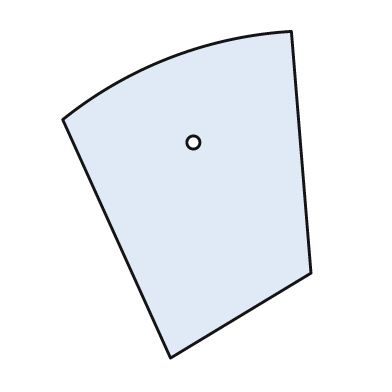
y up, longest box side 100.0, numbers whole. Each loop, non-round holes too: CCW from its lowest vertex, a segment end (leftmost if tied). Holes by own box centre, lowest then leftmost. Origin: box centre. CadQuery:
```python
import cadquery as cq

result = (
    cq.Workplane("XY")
    .moveTo(-5.0, -50.0)
    .lineTo(38.0, -24.0)
    .lineTo(32.0, 50.0)
    .threePointArc((-5.0, 42.0), (-38.0, 23.0))
    .close()
    .moveTo(2.0, 16.0)
    .circle(2.0)
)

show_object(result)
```